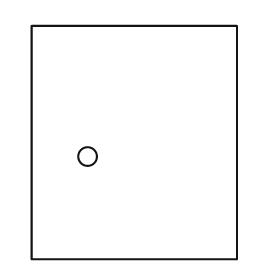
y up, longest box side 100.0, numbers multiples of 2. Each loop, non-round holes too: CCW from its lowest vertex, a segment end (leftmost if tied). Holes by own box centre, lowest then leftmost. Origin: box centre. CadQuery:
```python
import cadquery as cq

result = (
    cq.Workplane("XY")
    .moveTo(-44.0, -50.0)
    .lineTo(44.0, -50.0)
    .lineTo(44.0, 50.0)
    .lineTo(-44.0, 50.0)
    .close()
    .moveTo(-20.0, -6.0)
    .circle(4.0)
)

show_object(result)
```